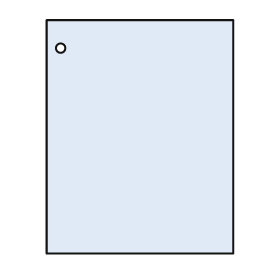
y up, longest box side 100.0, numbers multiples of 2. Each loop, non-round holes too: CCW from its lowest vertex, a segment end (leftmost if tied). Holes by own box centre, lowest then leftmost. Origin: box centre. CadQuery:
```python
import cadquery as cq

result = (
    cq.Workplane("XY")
    .moveTo(-40.0, -50.0)
    .lineTo(40.0, -50.0)
    .lineTo(40.0, 50.0)
    .lineTo(-40.0, 50.0)
    .close()
    .moveTo(-34.0, 38.0)
    .circle(2.0)
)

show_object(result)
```